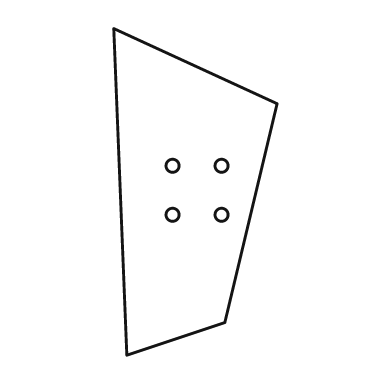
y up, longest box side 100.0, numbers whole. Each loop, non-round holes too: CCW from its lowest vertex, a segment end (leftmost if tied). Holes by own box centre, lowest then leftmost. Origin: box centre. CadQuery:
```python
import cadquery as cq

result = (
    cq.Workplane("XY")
    .moveTo(-21.0, -50.0)
    .lineTo(9.0, -40.0)
    .lineTo(25.0, 27.0)
    .lineTo(-25.0, 50.0)
    .close()
    .moveTo(-7.0, -7.0)
    .circle(2.0)
    .moveTo(8.0, -7.0)
    .circle(2.0)
    .moveTo(-7.0, 8.0)
    .circle(2.0)
    .moveTo(8.0, 8.0)
    .circle(2.0)
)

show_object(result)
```